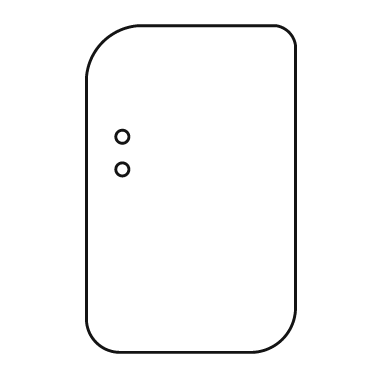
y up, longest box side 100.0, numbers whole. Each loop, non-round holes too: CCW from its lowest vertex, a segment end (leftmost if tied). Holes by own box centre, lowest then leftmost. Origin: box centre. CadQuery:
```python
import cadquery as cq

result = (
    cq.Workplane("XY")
    .moveTo(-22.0, -50.0)
    .lineTo(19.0, -50.0)
    .threePointArc((28.0, -46.0), (32.0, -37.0))
    .lineTo(32.0, 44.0)
    .threePointArc((30.0, 48.0), (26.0, 50.0))
    .lineTo(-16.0, 50.0)
    .threePointArc((-27.0, 45.0), (-32.0, 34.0))
    .lineTo(-32.0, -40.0)
    .threePointArc((-29.0, -47.0), (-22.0, -50.0))
    .close()
    .moveTo(-21.0, 6.0)
    .circle(2.0)
    .moveTo(-21.0, 16.0)
    .circle(2.0)
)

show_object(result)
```